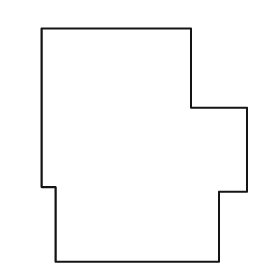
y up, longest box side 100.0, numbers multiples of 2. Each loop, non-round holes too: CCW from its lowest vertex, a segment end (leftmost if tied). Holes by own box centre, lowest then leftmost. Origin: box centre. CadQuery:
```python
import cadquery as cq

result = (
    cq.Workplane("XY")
    .moveTo(-38.0, -50.0)
    .lineTo(32.0, -50.0)
    .lineTo(32.0, -20.0)
    .lineTo(44.0, -20.0)
    .lineTo(44.0, 16.0)
    .lineTo(20.0, 16.0)
    .lineTo(20.0, 50.0)
    .lineTo(-44.0, 50.0)
    .lineTo(-44.0, -18.0)
    .lineTo(-38.0, -18.0)
    .close()
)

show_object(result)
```